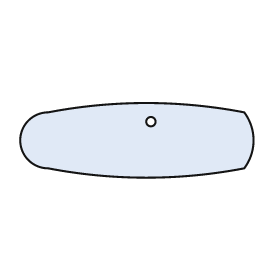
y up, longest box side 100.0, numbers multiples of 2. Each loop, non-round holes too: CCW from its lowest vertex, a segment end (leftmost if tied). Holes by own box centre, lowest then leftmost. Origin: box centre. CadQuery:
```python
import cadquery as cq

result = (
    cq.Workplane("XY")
    .moveTo(-38.0, -12.0)
    .threePointArc((4.0, -16.0), (46.0, -12.0))
    .threePointArc((50.0, 0.0), (46.0, 12.0))
    .threePointArc((4.0, 16.0), (-38.0, 12.0))
    .threePointArc((-50.0, 0.0), (-38.0, -12.0))
    .close()
    .moveTo(6.0, 8.0)
    .circle(2.0)
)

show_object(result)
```